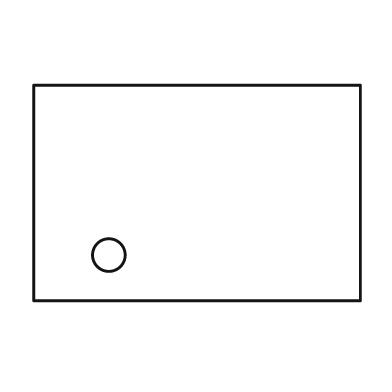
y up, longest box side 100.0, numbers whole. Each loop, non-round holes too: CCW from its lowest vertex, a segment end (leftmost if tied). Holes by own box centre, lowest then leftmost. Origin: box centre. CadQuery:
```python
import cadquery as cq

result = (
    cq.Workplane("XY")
    .moveTo(-50.0, -33.0)
    .lineTo(50.0, -33.0)
    .lineTo(50.0, 33.0)
    .lineTo(-50.0, 33.0)
    .close()
    .moveTo(-27.0, -19.0)
    .circle(5.0)
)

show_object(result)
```